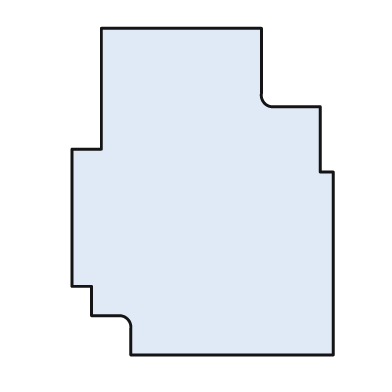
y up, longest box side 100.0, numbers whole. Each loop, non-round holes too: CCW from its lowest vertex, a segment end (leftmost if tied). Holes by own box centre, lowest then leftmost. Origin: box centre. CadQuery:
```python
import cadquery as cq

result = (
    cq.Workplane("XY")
    .moveTo(-22.0, -50.0)
    .lineTo(40.0, -50.0)
    .lineTo(40.0, 6.0)
    .lineTo(36.0, 6.0)
    .lineTo(36.0, 26.0)
    .lineTo(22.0, 26.0)
    .threePointArc((19.0, 27.0), (18.0, 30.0))
    .lineTo(18.0, 50.0)
    .lineTo(-31.0, 50.0)
    .lineTo(-31.0, 13.0)
    .lineTo(-40.0, 13.0)
    .lineTo(-40.0, -29.0)
    .lineTo(-34.0, -29.0)
    .lineTo(-34.0, -38.0)
    .lineTo(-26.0, -38.0)
    .threePointArc((-23.0, -39.0), (-22.0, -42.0))
    .close()
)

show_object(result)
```